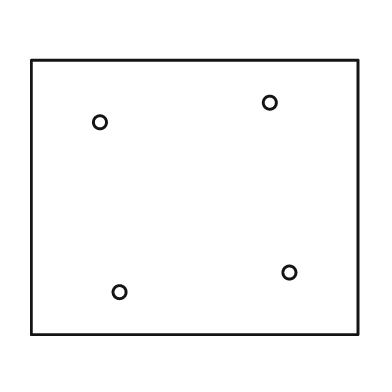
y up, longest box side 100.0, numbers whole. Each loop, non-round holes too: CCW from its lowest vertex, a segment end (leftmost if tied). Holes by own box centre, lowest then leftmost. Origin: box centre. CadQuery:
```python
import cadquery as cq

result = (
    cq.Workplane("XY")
    .moveTo(-50.0, -42.0)
    .lineTo(50.0, -42.0)
    .lineTo(50.0, 42.0)
    .lineTo(-50.0, 42.0)
    .close()
    .moveTo(-23.0, -29.0)
    .circle(2.0)
    .moveTo(29.0, -23.0)
    .circle(2.0)
    .moveTo(-29.0, 23.0)
    .circle(2.0)
    .moveTo(23.0, 29.0)
    .circle(2.0)
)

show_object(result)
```